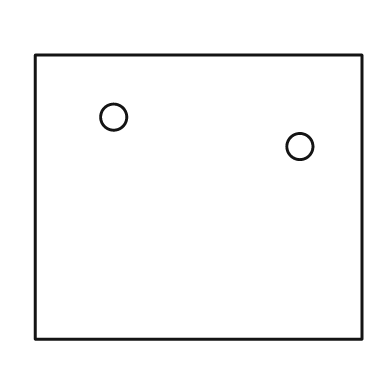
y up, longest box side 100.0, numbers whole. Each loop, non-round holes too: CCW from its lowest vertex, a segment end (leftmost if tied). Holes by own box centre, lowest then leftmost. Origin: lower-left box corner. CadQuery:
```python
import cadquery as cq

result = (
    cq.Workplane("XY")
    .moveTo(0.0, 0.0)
    .lineTo(100.0, 0.0)
    .lineTo(100.0, 87.0)
    .lineTo(0.0, 87.0)
    .close()
    .moveTo(81.0, 59.0)
    .circle(4.0)
    .moveTo(24.0, 68.0)
    .circle(4.0)
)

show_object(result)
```